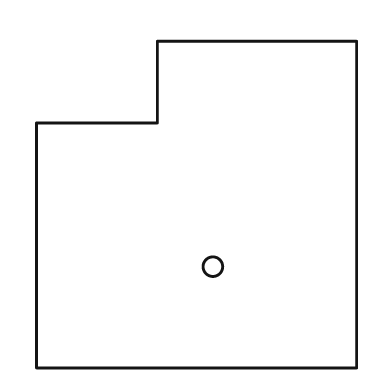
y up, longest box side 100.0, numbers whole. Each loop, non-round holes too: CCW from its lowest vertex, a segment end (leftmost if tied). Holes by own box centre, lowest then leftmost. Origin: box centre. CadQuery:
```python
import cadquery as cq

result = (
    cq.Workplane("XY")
    .moveTo(-49.0, -50.0)
    .lineTo(49.0, -50.0)
    .lineTo(49.0, 50.0)
    .lineTo(-12.0, 50.0)
    .lineTo(-12.0, 25.0)
    .lineTo(-49.0, 25.0)
    .close()
    .moveTo(5.0, -19.0)
    .circle(3.0)
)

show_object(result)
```